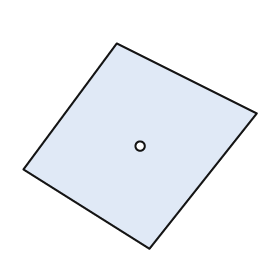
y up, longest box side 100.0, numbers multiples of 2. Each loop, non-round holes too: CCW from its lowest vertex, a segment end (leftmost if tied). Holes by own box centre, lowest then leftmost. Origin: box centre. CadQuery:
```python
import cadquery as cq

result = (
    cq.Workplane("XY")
    .moveTo(4.0, -44.0)
    .lineTo(50.0, 14.0)
    .lineTo(-10.0, 44.0)
    .lineTo(-50.0, -10.0)
    .close()
    .moveTo(0.0, 0.0)
    .circle(2.0)
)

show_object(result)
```